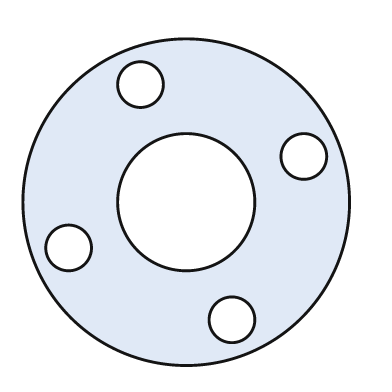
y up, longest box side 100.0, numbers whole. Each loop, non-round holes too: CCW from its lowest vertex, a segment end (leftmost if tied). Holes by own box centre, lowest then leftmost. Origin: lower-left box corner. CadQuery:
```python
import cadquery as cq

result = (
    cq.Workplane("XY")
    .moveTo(50.0, 50.0)
    .circle(50.0)
    .moveTo(64.0, 14.0)
    .circle(7.0)
    .moveTo(14.0, 36.0)
    .circle(7.0)
    .moveTo(50.0, 50.0)
    .circle(21.0)
    .moveTo(86.0, 64.0)
    .circle(7.0)
    .moveTo(36.0, 86.0)
    .circle(7.0)
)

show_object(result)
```